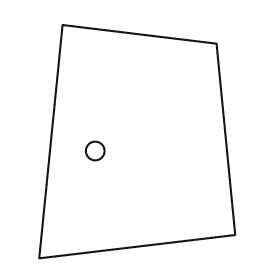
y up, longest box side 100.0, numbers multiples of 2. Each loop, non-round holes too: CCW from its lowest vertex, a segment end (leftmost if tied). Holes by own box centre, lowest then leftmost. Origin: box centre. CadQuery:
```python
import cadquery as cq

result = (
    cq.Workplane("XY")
    .moveTo(-42.0, -50.0)
    .lineTo(42.0, -40.0)
    .lineTo(34.0, 42.0)
    .lineTo(-32.0, 50.0)
    .close()
    .moveTo(-18.0, -4.0)
    .circle(4.0)
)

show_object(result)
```